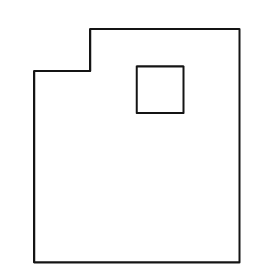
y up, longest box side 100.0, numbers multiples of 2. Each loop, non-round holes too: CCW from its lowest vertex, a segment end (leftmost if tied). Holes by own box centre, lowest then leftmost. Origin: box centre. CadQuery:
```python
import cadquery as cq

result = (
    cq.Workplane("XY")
    .moveTo(-44.0, -50.0)
    .lineTo(44.0, -50.0)
    .lineTo(44.0, 50.0)
    .lineTo(-20.0, 50.0)
    .lineTo(-20.0, 32.0)
    .lineTo(-44.0, 32.0)
    .close()
    .moveTo(0.0, 14.0)
    .lineTo(20.0, 14.0)
    .lineTo(20.0, 34.0)
    .lineTo(0.0, 34.0)
    .close()
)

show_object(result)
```